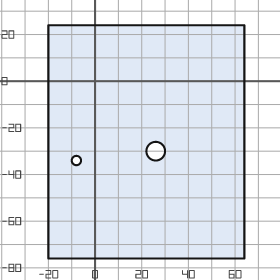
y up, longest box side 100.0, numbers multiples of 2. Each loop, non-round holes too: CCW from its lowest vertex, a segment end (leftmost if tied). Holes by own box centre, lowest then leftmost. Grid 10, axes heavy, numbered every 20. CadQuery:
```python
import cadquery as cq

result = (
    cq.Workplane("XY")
    .moveTo(-20.0, -76.0)
    .lineTo(64.0, -76.0)
    .lineTo(64.0, 24.0)
    .lineTo(-20.0, 24.0)
    .close()
    .moveTo(-8.0, -34.0)
    .circle(2.0)
    .moveTo(26.0, -30.0)
    .circle(4.0)
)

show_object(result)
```